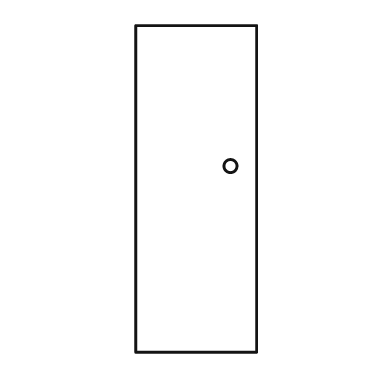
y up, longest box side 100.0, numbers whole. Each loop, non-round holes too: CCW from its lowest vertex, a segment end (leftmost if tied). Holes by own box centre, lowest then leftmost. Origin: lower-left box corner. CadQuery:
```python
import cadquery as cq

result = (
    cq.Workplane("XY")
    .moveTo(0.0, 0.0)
    .lineTo(37.0, 0.0)
    .lineTo(37.0, 100.0)
    .lineTo(0.0, 100.0)
    .close()
    .moveTo(29.0, 57.0)
    .circle(2.0)
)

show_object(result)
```